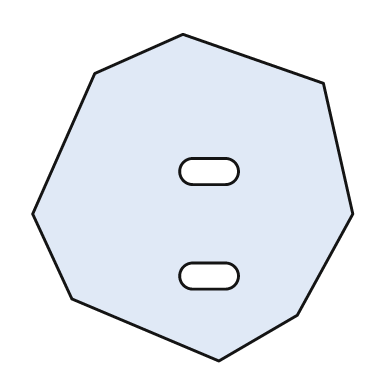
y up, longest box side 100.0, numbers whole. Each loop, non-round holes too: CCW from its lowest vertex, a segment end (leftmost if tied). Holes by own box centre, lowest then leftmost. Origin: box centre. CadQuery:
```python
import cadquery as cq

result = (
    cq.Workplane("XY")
    .moveTo(8.0, -50.0)
    .lineTo(32.0, -36.0)
    .lineTo(49.0, -5.0)
    .lineTo(40.0, 35.0)
    .lineTo(-3.0, 50.0)
    .lineTo(-30.0, 38.0)
    .lineTo(-49.0, -5.0)
    .lineTo(-37.0, -31.0)
    .close()
    .moveTo(0.0, -28.0)
    .lineTo(10.0, -28.0)
    .threePointArc((14.0, -24.0), (10.0, -20.0))
    .lineTo(0.0, -20.0)
    .threePointArc((-4.0, -24.0), (0.0, -28.0))
    .close()
    .moveTo(0.0, 4.0)
    .lineTo(10.0, 4.0)
    .threePointArc((14.0, 8.0), (10.0, 12.0))
    .lineTo(0.0, 12.0)
    .threePointArc((-4.0, 8.0), (0.0, 4.0))
    .close()
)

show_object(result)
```